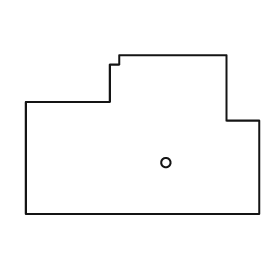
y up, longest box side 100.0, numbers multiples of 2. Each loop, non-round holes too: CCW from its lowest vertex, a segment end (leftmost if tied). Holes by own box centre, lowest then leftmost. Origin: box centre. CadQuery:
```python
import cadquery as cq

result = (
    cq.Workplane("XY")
    .moveTo(-50.0, -34.0)
    .lineTo(50.0, -34.0)
    .lineTo(50.0, 6.0)
    .lineTo(36.0, 6.0)
    .lineTo(36.0, 34.0)
    .lineTo(-10.0, 34.0)
    .lineTo(-10.0, 30.0)
    .lineTo(-14.0, 30.0)
    .lineTo(-14.0, 14.0)
    .lineTo(-50.0, 14.0)
    .close()
    .moveTo(10.0, -12.0)
    .circle(2.0)
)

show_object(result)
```